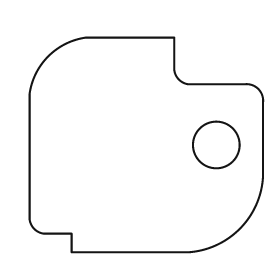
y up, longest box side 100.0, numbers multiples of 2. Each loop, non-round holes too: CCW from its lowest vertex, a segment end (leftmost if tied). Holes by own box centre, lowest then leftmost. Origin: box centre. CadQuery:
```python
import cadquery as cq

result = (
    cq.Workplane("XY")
    .moveTo(-32.0, -46.0)
    .lineTo(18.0, -46.0)
    .threePointArc((40.0, -36.0), (50.0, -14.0))
    .lineTo(50.0, 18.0)
    .threePointArc((48.0, 24.0), (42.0, 26.0))
    .lineTo(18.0, 26.0)
    .threePointArc((14.0, 28.0), (12.0, 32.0))
    .lineTo(12.0, 46.0)
    .lineTo(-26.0, 46.0)
    .threePointArc((-42.0, 38.0), (-50.0, 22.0))
    .lineTo(-50.0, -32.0)
    .threePointArc((-48.0, -36.0), (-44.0, -38.0))
    .lineTo(-32.0, -38.0)
    .close()
    .moveTo(30.0, 0.0)
    .circle(10.0)
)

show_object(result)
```